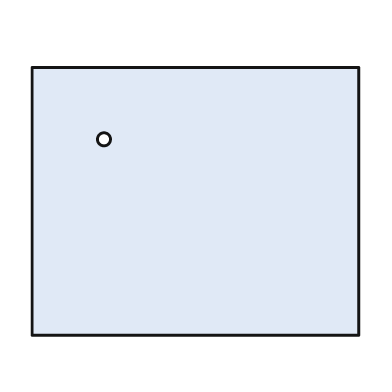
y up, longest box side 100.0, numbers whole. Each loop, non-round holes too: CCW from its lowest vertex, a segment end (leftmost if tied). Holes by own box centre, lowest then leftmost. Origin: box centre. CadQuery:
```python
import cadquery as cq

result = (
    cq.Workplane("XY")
    .moveTo(-50.0, -41.0)
    .lineTo(50.0, -41.0)
    .lineTo(50.0, 41.0)
    .lineTo(-50.0, 41.0)
    .close()
    .moveTo(-28.0, 19.0)
    .circle(2.0)
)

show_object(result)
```